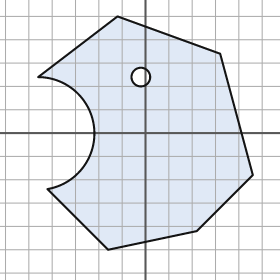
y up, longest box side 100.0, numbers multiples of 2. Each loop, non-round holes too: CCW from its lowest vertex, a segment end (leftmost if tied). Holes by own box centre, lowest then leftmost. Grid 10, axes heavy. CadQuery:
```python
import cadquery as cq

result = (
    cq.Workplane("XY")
    .moveTo(-16.0, -50.0)
    .lineTo(22.0, -42.0)
    .lineTo(46.0, -18.0)
    .lineTo(32.0, 34.0)
    .lineTo(-12.0, 50.0)
    .lineTo(-46.0, 24.0)
    .threePointArc((-22.0, 2.0), (-42.0, -24.0))
    .close()
    .moveTo(-2.0, 24.0)
    .circle(4.0)
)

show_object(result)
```